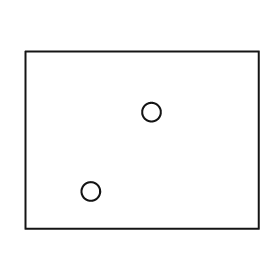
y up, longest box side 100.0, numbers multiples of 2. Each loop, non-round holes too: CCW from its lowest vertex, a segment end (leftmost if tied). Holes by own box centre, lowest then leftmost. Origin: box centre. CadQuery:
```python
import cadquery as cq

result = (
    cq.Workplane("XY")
    .moveTo(-50.0, -38.0)
    .lineTo(50.0, -38.0)
    .lineTo(50.0, 38.0)
    .lineTo(-50.0, 38.0)
    .close()
    .moveTo(-22.0, -22.0)
    .circle(4.0)
    .moveTo(4.0, 12.0)
    .circle(4.0)
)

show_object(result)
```